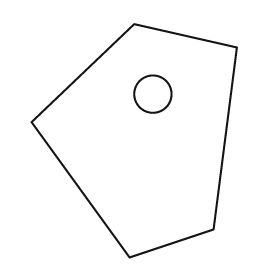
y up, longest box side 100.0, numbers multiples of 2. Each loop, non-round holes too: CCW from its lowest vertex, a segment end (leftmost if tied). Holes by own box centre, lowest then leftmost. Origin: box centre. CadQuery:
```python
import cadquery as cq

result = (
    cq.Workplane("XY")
    .moveTo(-2.0, -50.0)
    .lineTo(34.0, -38.0)
    .lineTo(44.0, 40.0)
    .lineTo(0.0, 50.0)
    .lineTo(-44.0, 8.0)
    .close()
    .moveTo(8.0, 20.0)
    .circle(8.0)
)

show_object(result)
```